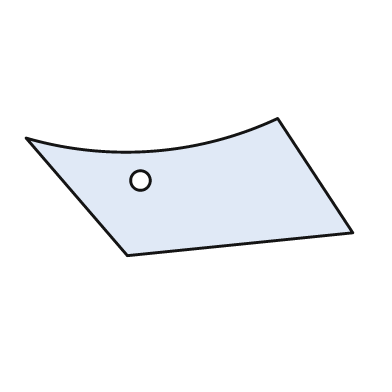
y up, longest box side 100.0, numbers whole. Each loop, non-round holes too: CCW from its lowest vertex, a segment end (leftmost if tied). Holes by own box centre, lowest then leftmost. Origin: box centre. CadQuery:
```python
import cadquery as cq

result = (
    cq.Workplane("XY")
    .moveTo(-19.0, -21.0)
    .lineTo(50.0, -14.0)
    .lineTo(27.0, 21.0)
    .threePointArc((-11.0, 11.0), (-50.0, 15.0))
    .close()
    .moveTo(-15.0, 2.0)
    .circle(3.0)
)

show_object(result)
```